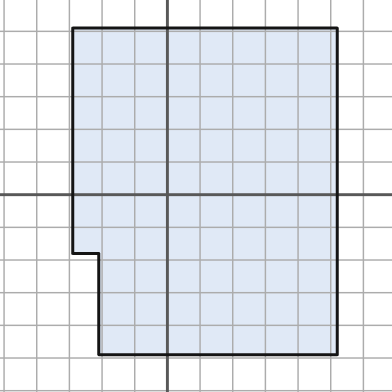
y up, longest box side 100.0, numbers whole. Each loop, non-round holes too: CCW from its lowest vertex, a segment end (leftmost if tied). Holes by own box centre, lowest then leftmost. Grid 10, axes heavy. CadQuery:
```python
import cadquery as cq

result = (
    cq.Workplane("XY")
    .moveTo(-21.0, -49.0)
    .lineTo(52.0, -49.0)
    .lineTo(52.0, 51.0)
    .lineTo(-29.0, 51.0)
    .lineTo(-29.0, -18.0)
    .lineTo(-21.0, -18.0)
    .close()
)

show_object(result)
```